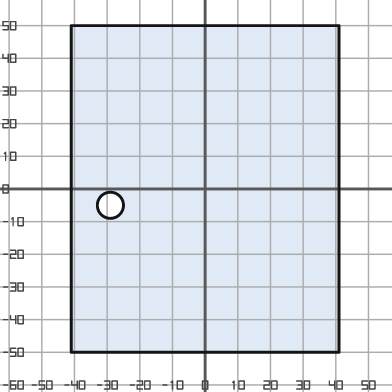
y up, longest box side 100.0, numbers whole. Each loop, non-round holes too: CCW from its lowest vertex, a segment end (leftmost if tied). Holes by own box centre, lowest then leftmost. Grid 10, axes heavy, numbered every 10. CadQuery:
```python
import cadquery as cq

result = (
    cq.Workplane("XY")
    .moveTo(-41.0, -50.0)
    .lineTo(41.0, -50.0)
    .lineTo(41.0, 50.0)
    .lineTo(-41.0, 50.0)
    .close()
    .moveTo(-29.0, -5.0)
    .circle(4.0)
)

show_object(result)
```